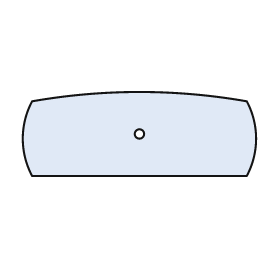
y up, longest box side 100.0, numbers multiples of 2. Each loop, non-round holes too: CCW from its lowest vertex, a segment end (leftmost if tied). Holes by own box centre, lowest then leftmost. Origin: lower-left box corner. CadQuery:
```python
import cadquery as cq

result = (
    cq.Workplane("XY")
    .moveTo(4.0, 0.0)
    .lineTo(96.0, 0.0)
    .threePointArc((100.0, 16.0), (96.0, 32.0))
    .threePointArc((50.0, 36.0), (4.0, 32.0))
    .threePointArc((0.0, 16.0), (4.0, 0.0))
    .close()
    .moveTo(50.0, 18.0)
    .circle(2.0)
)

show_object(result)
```